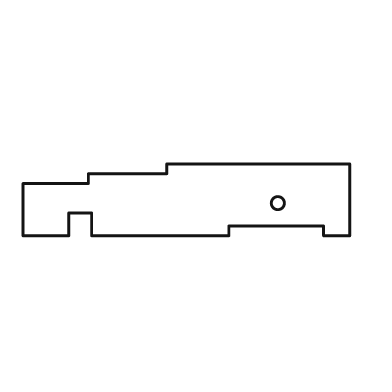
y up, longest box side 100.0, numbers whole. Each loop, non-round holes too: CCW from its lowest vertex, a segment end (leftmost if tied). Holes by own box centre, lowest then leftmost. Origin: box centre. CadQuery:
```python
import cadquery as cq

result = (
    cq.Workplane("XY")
    .moveTo(-50.0, -11.0)
    .lineTo(-36.0, -11.0)
    .lineTo(-36.0, -4.0)
    .lineTo(-29.0, -4.0)
    .lineTo(-29.0, -11.0)
    .lineTo(13.0, -11.0)
    .lineTo(13.0, -8.0)
    .lineTo(42.0, -8.0)
    .lineTo(42.0, -11.0)
    .lineTo(50.0, -11.0)
    .lineTo(50.0, 11.0)
    .lineTo(-6.0, 11.0)
    .lineTo(-6.0, 8.0)
    .lineTo(-30.0, 8.0)
    .lineTo(-30.0, 5.0)
    .lineTo(-50.0, 5.0)
    .close()
    .moveTo(28.0, -1.0)
    .circle(2.0)
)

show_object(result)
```